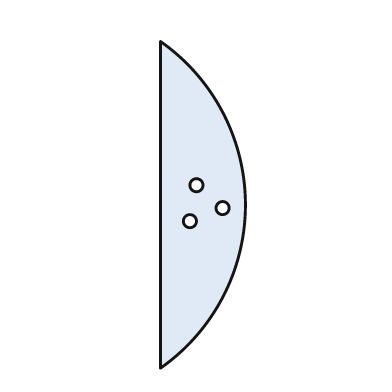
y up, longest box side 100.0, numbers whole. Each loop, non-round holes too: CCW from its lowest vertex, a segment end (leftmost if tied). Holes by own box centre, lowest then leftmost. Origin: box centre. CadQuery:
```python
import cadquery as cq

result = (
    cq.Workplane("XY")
    .moveTo(-13.0, -50.0)
    .threePointArc((13.0, 0.0), (-13.0, 50.0))
    .close()
    .moveTo(-4.0, -5.0)
    .circle(2.0)
    .moveTo(6.0, -1.0)
    .circle(2.0)
    .moveTo(-2.0, 6.0)
    .circle(2.0)
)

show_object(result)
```